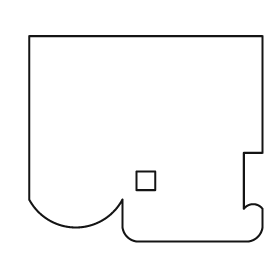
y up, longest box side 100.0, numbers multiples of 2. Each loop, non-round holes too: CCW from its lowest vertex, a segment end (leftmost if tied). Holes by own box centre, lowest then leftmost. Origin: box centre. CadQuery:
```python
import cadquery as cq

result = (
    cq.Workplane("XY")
    .moveTo(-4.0, -44.0)
    .lineTo(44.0, -44.0)
    .threePointArc((48.0, -42.0), (50.0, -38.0))
    .lineTo(50.0, -30.0)
    .threePointArc((46.0, -28.0), (42.0, -30.0))
    .lineTo(42.0, -6.0)
    .lineTo(50.0, -6.0)
    .lineTo(50.0, 44.0)
    .lineTo(-50.0, 44.0)
    .lineTo(-50.0, -26.0)
    .threePointArc((-30.0, -38.0), (-10.0, -26.0))
    .lineTo(-10.0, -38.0)
    .threePointArc((-8.0, -42.0), (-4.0, -44.0))
    .close()
    .moveTo(-4.0, -22.0)
    .lineTo(4.0, -22.0)
    .lineTo(4.0, -14.0)
    .lineTo(-4.0, -14.0)
    .close()
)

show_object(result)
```